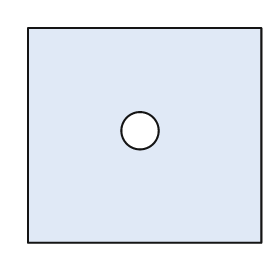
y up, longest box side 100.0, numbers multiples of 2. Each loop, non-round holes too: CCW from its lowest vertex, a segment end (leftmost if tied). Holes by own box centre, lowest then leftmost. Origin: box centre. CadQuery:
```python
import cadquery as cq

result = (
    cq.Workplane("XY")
    .moveTo(-50.0, -46.0)
    .lineTo(50.0, -46.0)
    .lineTo(50.0, 46.0)
    .lineTo(-50.0, 46.0)
    .close()
    .moveTo(-2.0, 2.0)
    .circle(8.0)
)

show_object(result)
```